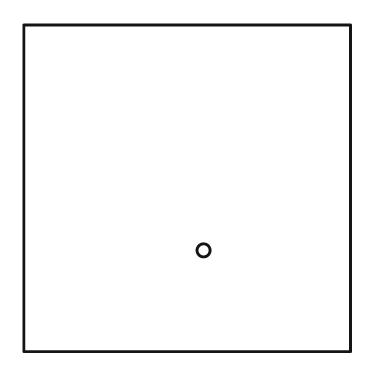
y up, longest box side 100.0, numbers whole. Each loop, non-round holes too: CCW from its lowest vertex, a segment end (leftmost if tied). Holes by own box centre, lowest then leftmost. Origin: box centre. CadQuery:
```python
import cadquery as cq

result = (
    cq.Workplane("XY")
    .moveTo(-50.0, -50.0)
    .lineTo(50.0, -50.0)
    .lineTo(50.0, 50.0)
    .lineTo(-50.0, 50.0)
    .close()
    .moveTo(5.0, -19.0)
    .circle(2.0)
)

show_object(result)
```